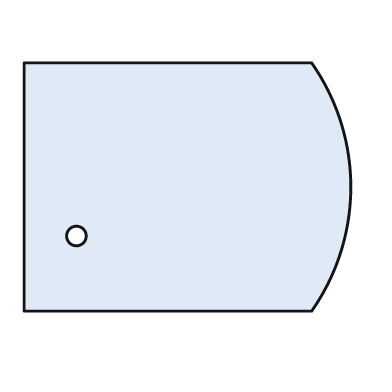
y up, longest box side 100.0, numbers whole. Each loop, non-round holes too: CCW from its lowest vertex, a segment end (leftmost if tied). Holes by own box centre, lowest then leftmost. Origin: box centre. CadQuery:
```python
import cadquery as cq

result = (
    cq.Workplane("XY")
    .moveTo(-50.0, -38.0)
    .lineTo(38.0, -38.0)
    .threePointArc((50.0, 0.0), (38.0, 38.0))
    .lineTo(-50.0, 38.0)
    .close()
    .moveTo(-34.0, -15.0)
    .circle(3.0)
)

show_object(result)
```